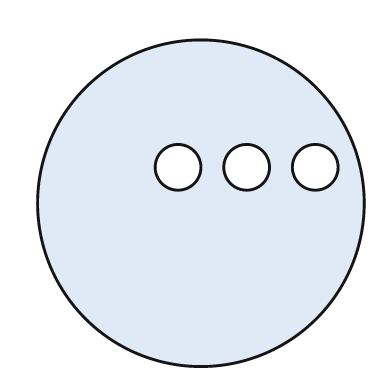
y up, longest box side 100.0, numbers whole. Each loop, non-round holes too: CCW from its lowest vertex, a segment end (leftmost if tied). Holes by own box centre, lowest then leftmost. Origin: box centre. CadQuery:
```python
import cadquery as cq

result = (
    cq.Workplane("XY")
    .moveTo(0.0, 0.0)
    .circle(50.0)
    .moveTo(-7.0, 11.0)
    .circle(7.0)
    .moveTo(14.0, 11.0)
    .circle(7.0)
    .moveTo(35.0, 11.0)
    .circle(7.0)
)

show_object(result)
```